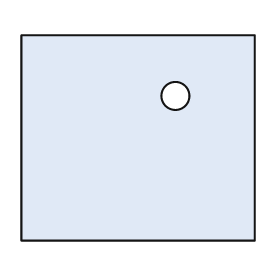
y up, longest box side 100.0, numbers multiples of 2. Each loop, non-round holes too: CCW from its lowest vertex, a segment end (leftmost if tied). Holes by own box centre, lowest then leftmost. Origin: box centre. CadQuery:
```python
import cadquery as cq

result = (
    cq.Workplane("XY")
    .moveTo(-50.0, -44.0)
    .lineTo(50.0, -44.0)
    .lineTo(50.0, 44.0)
    .lineTo(-50.0, 44.0)
    .close()
    .moveTo(16.0, 18.0)
    .circle(6.0)
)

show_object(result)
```